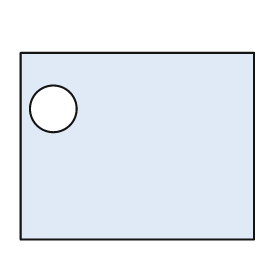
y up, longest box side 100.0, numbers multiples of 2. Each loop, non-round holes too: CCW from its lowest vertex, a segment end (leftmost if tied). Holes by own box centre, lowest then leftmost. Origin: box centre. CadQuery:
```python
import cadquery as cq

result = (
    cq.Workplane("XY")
    .moveTo(-50.0, -40.0)
    .lineTo(50.0, -40.0)
    .lineTo(50.0, 40.0)
    .lineTo(-50.0, 40.0)
    .close()
    .moveTo(-36.0, 16.0)
    .circle(10.0)
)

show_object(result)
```